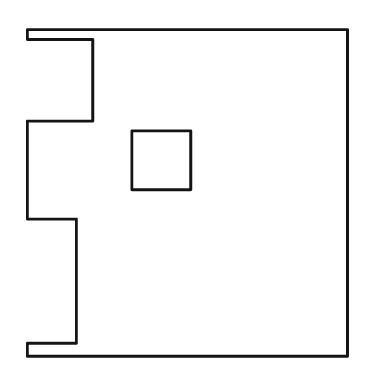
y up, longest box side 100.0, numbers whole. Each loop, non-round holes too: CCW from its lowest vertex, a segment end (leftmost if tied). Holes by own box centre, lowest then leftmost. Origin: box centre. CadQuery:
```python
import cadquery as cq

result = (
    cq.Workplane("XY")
    .moveTo(-49.0, -50.0)
    .lineTo(49.0, -50.0)
    .lineTo(49.0, 50.0)
    .lineTo(-49.0, 50.0)
    .lineTo(-49.0, 47.0)
    .lineTo(-29.0, 47.0)
    .lineTo(-29.0, 22.0)
    .lineTo(-49.0, 22.0)
    .lineTo(-49.0, -8.0)
    .lineTo(-34.0, -8.0)
    .lineTo(-34.0, -46.0)
    .lineTo(-49.0, -46.0)
    .close()
    .moveTo(-17.0, 1.0)
    .lineTo(1.0, 1.0)
    .lineTo(1.0, 19.0)
    .lineTo(-17.0, 19.0)
    .close()
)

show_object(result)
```